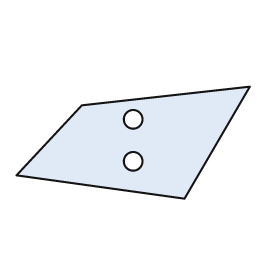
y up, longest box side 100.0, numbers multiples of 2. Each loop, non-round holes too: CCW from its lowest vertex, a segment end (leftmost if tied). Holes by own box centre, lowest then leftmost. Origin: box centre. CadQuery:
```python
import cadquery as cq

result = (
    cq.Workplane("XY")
    .moveTo(22.0, -24.0)
    .lineTo(50.0, 24.0)
    .lineTo(-22.0, 16.0)
    .lineTo(-50.0, -14.0)
    .close()
    .moveTo(0.0, -8.0)
    .circle(4.0)
    .moveTo(0.0, 10.0)
    .circle(4.0)
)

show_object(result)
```